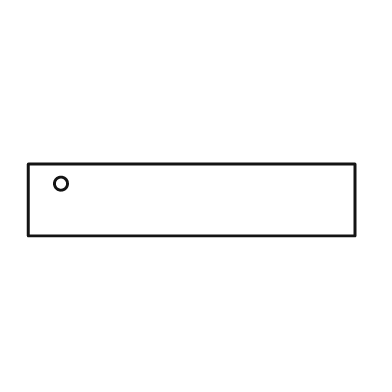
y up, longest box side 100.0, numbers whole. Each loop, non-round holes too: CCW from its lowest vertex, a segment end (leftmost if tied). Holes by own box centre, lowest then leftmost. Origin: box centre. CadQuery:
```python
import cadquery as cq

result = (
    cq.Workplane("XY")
    .moveTo(-50.0, -11.0)
    .lineTo(50.0, -11.0)
    .lineTo(50.0, 11.0)
    .lineTo(-50.0, 11.0)
    .close()
    .moveTo(-40.0, 5.0)
    .circle(2.0)
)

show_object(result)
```